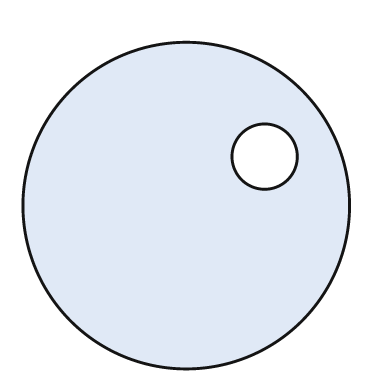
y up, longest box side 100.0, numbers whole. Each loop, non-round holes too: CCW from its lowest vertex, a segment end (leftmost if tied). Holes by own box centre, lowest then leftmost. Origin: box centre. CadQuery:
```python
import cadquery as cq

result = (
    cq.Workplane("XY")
    .moveTo(0.0, 0.0)
    .circle(50.0)
    .moveTo(24.0, 15.0)
    .circle(10.0)
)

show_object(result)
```